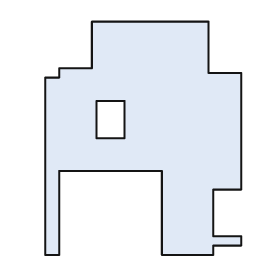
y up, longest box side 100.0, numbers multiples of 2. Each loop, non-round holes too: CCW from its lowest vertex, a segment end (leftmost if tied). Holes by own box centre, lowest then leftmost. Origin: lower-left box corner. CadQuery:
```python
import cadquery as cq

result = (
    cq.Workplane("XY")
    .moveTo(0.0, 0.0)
    .lineTo(6.0, 0.0)
    .lineTo(6.0, 36.0)
    .lineTo(50.0, 36.0)
    .lineTo(50.0, 0.0)
    .lineTo(72.0, 0.0)
    .lineTo(72.0, 4.0)
    .lineTo(84.0, 4.0)
    .lineTo(84.0, 8.0)
    .lineTo(72.0, 8.0)
    .lineTo(72.0, 28.0)
    .lineTo(84.0, 28.0)
    .lineTo(84.0, 78.0)
    .lineTo(70.0, 78.0)
    .lineTo(70.0, 100.0)
    .lineTo(20.0, 100.0)
    .lineTo(20.0, 80.0)
    .lineTo(6.0, 80.0)
    .lineTo(6.0, 76.0)
    .lineTo(0.0, 76.0)
    .close()
    .moveTo(22.0, 50.0)
    .lineTo(34.0, 50.0)
    .lineTo(34.0, 66.0)
    .lineTo(22.0, 66.0)
    .close()
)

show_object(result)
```